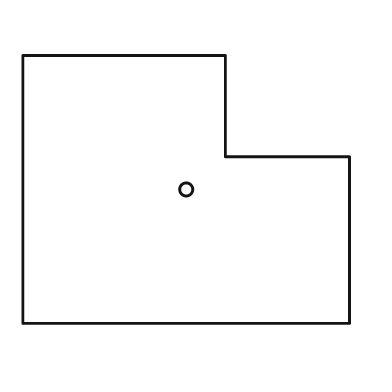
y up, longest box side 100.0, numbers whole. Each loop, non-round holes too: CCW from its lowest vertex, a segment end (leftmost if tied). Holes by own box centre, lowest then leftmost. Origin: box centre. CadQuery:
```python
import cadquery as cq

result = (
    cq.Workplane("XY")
    .moveTo(-50.0, -41.0)
    .lineTo(50.0, -41.0)
    .lineTo(50.0, 10.0)
    .lineTo(12.0, 10.0)
    .lineTo(12.0, 41.0)
    .lineTo(-50.0, 41.0)
    .close()
    .moveTo(0.0, 0.0)
    .circle(2.0)
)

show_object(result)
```